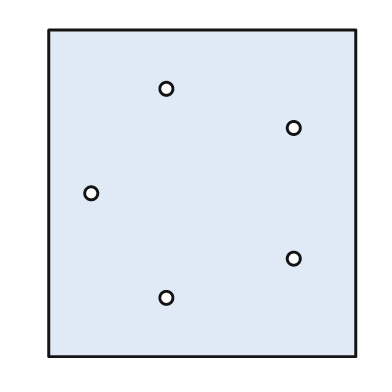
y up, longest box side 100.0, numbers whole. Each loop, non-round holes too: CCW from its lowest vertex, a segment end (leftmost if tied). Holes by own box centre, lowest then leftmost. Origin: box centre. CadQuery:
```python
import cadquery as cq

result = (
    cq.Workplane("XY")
    .moveTo(-47.0, -50.0)
    .lineTo(47.0, -50.0)
    .lineTo(47.0, 50.0)
    .lineTo(-47.0, 50.0)
    .close()
    .moveTo(-11.0, -32.0)
    .circle(2.0)
    .moveTo(28.0, -20.0)
    .circle(2.0)
    .moveTo(-34.0, 0.0)
    .circle(2.0)
    .moveTo(28.0, 20.0)
    .circle(2.0)
    .moveTo(-11.0, 32.0)
    .circle(2.0)
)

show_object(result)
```